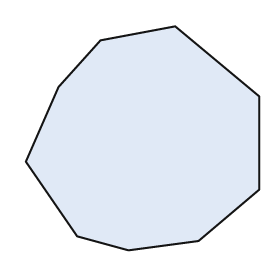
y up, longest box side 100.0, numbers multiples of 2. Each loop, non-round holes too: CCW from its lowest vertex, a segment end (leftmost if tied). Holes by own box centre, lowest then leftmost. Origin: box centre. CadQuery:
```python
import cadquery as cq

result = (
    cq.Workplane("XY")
    .moveTo(-6.0, -48.0)
    .lineTo(24.0, -44.0)
    .lineTo(50.0, -22.0)
    .lineTo(50.0, 18.0)
    .lineTo(14.0, 48.0)
    .lineTo(-18.0, 42.0)
    .lineTo(-36.0, 22.0)
    .lineTo(-50.0, -10.0)
    .lineTo(-28.0, -42.0)
    .close()
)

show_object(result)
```